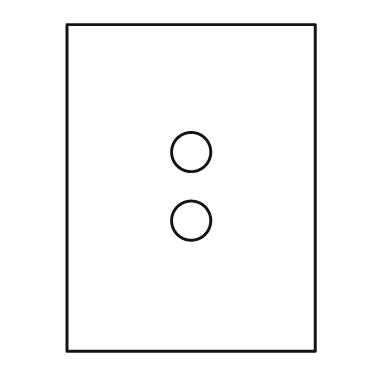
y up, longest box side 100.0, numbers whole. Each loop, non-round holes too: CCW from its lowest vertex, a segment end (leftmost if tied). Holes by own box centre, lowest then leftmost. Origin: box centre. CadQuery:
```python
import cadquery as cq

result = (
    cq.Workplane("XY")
    .moveTo(-38.0, -50.0)
    .lineTo(38.0, -50.0)
    .lineTo(38.0, 50.0)
    .lineTo(-38.0, 50.0)
    .close()
    .moveTo(0.0, -10.0)
    .circle(6.0)
    .moveTo(0.0, 11.0)
    .circle(6.0)
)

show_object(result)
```